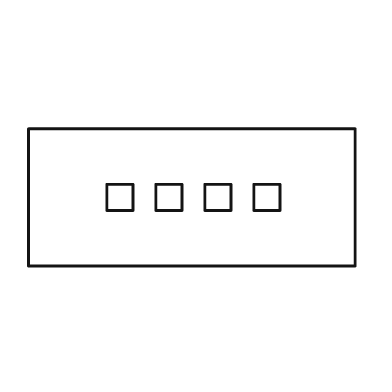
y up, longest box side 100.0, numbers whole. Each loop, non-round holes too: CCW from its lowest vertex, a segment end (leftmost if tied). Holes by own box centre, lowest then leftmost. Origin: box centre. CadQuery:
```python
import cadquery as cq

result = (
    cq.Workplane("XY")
    .moveTo(-50.0, -21.0)
    .lineTo(50.0, -21.0)
    .lineTo(50.0, 21.0)
    .lineTo(-50.0, 21.0)
    .close()
    .moveTo(-26.0, -4.0)
    .lineTo(-18.0, -4.0)
    .lineTo(-18.0, 4.0)
    .lineTo(-26.0, 4.0)
    .close()
    .moveTo(-11.0, -4.0)
    .lineTo(-3.0, -4.0)
    .lineTo(-3.0, 4.0)
    .lineTo(-11.0, 4.0)
    .close()
    .moveTo(4.0, -4.0)
    .lineTo(12.0, -4.0)
    .lineTo(12.0, 4.0)
    .lineTo(4.0, 4.0)
    .close()
    .moveTo(19.0, -4.0)
    .lineTo(27.0, -4.0)
    .lineTo(27.0, 4.0)
    .lineTo(19.0, 4.0)
    .close()
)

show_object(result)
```